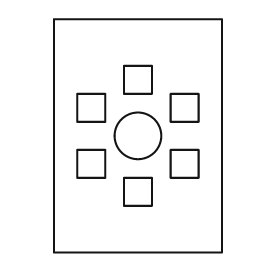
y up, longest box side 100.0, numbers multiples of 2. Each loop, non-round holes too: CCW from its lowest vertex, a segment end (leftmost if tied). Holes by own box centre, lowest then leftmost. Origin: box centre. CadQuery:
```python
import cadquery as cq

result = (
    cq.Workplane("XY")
    .moveTo(-36.0, -50.0)
    .lineTo(36.0, -50.0)
    .lineTo(36.0, 50.0)
    .lineTo(-36.0, 50.0)
    .close()
    .moveTo(-6.0, -30.0)
    .lineTo(6.0, -30.0)
    .lineTo(6.0, -18.0)
    .lineTo(-6.0, -18.0)
    .close()
    .moveTo(-26.0, -18.0)
    .lineTo(-14.0, -18.0)
    .lineTo(-14.0, -6.0)
    .lineTo(-26.0, -6.0)
    .close()
    .moveTo(14.0, -18.0)
    .lineTo(26.0, -18.0)
    .lineTo(26.0, -6.0)
    .lineTo(14.0, -6.0)
    .close()
    .moveTo(0.0, 0.0)
    .circle(10.0)
    .moveTo(-26.0, 6.0)
    .lineTo(-14.0, 6.0)
    .lineTo(-14.0, 18.0)
    .lineTo(-26.0, 18.0)
    .close()
    .moveTo(14.0, 6.0)
    .lineTo(26.0, 6.0)
    .lineTo(26.0, 18.0)
    .lineTo(14.0, 18.0)
    .close()
    .moveTo(-6.0, 18.0)
    .lineTo(6.0, 18.0)
    .lineTo(6.0, 30.0)
    .lineTo(-6.0, 30.0)
    .close()
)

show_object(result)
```